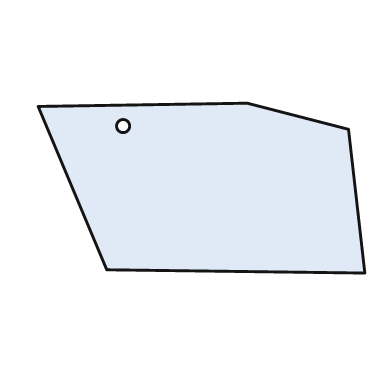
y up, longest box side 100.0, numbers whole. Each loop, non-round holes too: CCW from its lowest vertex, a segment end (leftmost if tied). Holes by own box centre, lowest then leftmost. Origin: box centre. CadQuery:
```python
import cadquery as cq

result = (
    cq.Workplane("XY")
    .moveTo(50.0, -26.0)
    .lineTo(45.0, 18.0)
    .lineTo(14.0, 26.0)
    .lineTo(-50.0, 25.0)
    .lineTo(-29.0, -25.0)
    .close()
    .moveTo(-24.0, 19.0)
    .circle(2.0)
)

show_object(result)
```